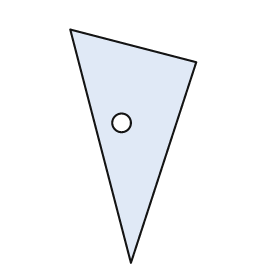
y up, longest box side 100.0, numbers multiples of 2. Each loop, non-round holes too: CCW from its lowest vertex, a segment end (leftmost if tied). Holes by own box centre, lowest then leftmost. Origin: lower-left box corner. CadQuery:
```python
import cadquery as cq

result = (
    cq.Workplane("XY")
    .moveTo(26.0, 0.0)
    .lineTo(54.0, 86.0)
    .lineTo(0.0, 100.0)
    .close()
    .moveTo(22.0, 60.0)
    .circle(4.0)
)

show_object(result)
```